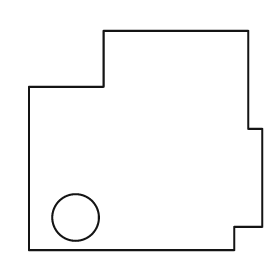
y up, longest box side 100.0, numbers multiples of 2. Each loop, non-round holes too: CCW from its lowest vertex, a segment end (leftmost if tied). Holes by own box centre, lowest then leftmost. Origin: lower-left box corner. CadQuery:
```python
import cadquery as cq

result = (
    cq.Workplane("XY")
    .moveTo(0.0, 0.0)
    .lineTo(88.0, 0.0)
    .lineTo(88.0, 10.0)
    .lineTo(100.0, 10.0)
    .lineTo(100.0, 52.0)
    .lineTo(94.0, 52.0)
    .lineTo(94.0, 94.0)
    .lineTo(32.0, 94.0)
    .lineTo(32.0, 70.0)
    .lineTo(0.0, 70.0)
    .close()
    .moveTo(20.0, 14.0)
    .circle(10.0)
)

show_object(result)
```